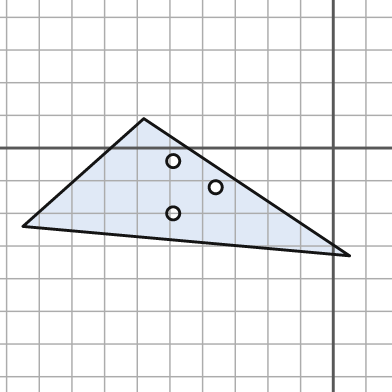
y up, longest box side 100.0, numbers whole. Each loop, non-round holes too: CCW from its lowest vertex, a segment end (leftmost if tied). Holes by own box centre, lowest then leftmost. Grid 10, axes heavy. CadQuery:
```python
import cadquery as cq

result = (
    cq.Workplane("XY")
    .moveTo(5.0, -33.0)
    .lineTo(-58.0, 9.0)
    .lineTo(-95.0, -24.0)
    .close()
    .moveTo(-49.0, -20.0)
    .circle(2.0)
    .moveTo(-36.0, -12.0)
    .circle(2.0)
    .moveTo(-49.0, -4.0)
    .circle(2.0)
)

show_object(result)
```